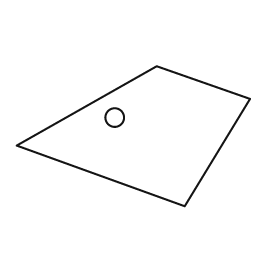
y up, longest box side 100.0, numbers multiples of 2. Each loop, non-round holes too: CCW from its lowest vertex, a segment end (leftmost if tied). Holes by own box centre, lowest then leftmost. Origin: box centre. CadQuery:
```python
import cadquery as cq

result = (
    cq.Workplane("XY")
    .moveTo(22.0, -30.0)
    .lineTo(50.0, 16.0)
    .lineTo(10.0, 30.0)
    .lineTo(-50.0, -4.0)
    .close()
    .moveTo(-8.0, 8.0)
    .circle(4.0)
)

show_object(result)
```